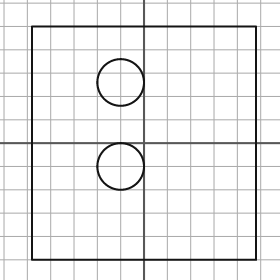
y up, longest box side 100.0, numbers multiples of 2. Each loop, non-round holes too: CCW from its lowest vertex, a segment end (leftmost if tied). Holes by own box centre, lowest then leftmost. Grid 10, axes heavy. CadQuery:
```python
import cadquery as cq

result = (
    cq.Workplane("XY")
    .moveTo(-48.0, -50.0)
    .lineTo(48.0, -50.0)
    .lineTo(48.0, 50.0)
    .lineTo(-48.0, 50.0)
    .close()
    .moveTo(-10.0, -10.0)
    .circle(10.0)
    .moveTo(-10.0, 26.0)
    .circle(10.0)
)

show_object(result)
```